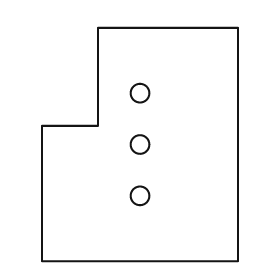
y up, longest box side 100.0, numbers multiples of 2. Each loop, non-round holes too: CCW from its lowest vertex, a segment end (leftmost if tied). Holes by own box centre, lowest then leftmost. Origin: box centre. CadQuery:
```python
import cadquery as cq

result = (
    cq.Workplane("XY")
    .moveTo(-42.0, -50.0)
    .lineTo(42.0, -50.0)
    .lineTo(42.0, 50.0)
    .lineTo(-18.0, 50.0)
    .lineTo(-18.0, 8.0)
    .lineTo(-42.0, 8.0)
    .close()
    .moveTo(0.0, -22.0)
    .circle(4.0)
    .moveTo(0.0, 0.0)
    .circle(4.0)
    .moveTo(0.0, 22.0)
    .circle(4.0)
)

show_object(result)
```